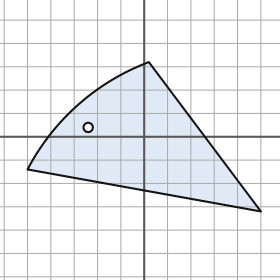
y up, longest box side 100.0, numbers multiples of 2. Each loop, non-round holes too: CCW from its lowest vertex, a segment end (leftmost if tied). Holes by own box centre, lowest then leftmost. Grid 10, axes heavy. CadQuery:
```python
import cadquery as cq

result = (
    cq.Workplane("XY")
    .moveTo(50.0, -32.0)
    .lineTo(2.0, 32.0)
    .threePointArc((-28.0, 14.0), (-50.0, -14.0))
    .close()
    .moveTo(-24.0, 4.0)
    .circle(2.0)
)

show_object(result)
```